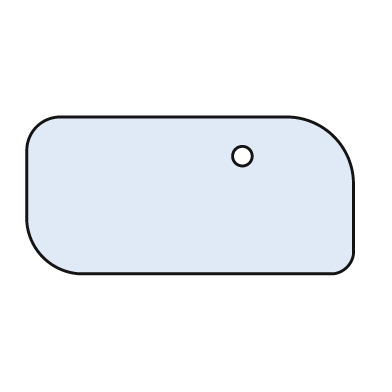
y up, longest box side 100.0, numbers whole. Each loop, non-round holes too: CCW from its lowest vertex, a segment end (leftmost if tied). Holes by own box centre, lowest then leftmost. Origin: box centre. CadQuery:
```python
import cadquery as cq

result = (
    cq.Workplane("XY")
    .moveTo(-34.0, -24.0)
    .lineTo(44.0, -24.0)
    .threePointArc((48.0, -22.0), (50.0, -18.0))
    .lineTo(50.0, 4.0)
    .threePointArc((44.0, 18.0), (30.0, 24.0))
    .lineTo(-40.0, 24.0)
    .threePointArc((-47.0, 21.0), (-50.0, 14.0))
    .lineTo(-50.0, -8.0)
    .threePointArc((-45.0, -19.0), (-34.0, -24.0))
    .close()
    .moveTo(16.0, 12.0)
    .circle(3.0)
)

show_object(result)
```